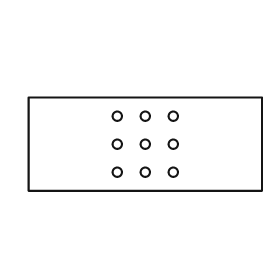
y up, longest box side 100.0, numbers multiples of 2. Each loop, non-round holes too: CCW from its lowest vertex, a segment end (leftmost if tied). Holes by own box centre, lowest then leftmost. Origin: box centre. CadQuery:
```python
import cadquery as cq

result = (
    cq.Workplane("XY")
    .moveTo(-50.0, -20.0)
    .lineTo(50.0, -20.0)
    .lineTo(50.0, 20.0)
    .lineTo(-50.0, 20.0)
    .close()
    .moveTo(-12.0, -12.0)
    .circle(2.0)
    .moveTo(0.0, -12.0)
    .circle(2.0)
    .moveTo(12.0, -12.0)
    .circle(2.0)
    .moveTo(-12.0, 0.0)
    .circle(2.0)
    .moveTo(0.0, 0.0)
    .circle(2.0)
    .moveTo(12.0, 0.0)
    .circle(2.0)
    .moveTo(-12.0, 12.0)
    .circle(2.0)
    .moveTo(0.0, 12.0)
    .circle(2.0)
    .moveTo(12.0, 12.0)
    .circle(2.0)
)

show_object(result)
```